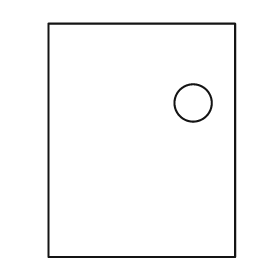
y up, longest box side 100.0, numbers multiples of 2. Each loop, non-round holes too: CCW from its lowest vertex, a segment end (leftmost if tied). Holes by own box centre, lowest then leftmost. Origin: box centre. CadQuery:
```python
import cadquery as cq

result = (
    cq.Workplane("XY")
    .moveTo(-40.0, -50.0)
    .lineTo(40.0, -50.0)
    .lineTo(40.0, 50.0)
    .lineTo(-40.0, 50.0)
    .close()
    .moveTo(22.0, 16.0)
    .circle(8.0)
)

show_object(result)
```